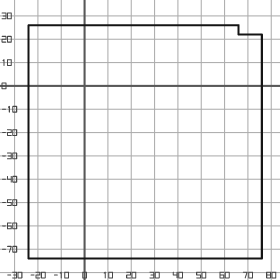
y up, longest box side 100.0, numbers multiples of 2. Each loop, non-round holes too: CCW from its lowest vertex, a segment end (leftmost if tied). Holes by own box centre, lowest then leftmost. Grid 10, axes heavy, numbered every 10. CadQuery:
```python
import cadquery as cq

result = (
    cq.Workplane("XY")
    .moveTo(-24.0, -74.0)
    .lineTo(76.0, -74.0)
    .lineTo(76.0, 22.0)
    .lineTo(66.0, 22.0)
    .lineTo(66.0, 26.0)
    .lineTo(-24.0, 26.0)
    .close()
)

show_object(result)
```